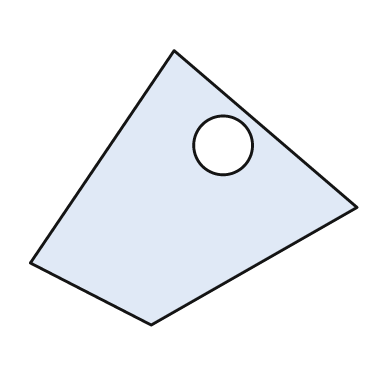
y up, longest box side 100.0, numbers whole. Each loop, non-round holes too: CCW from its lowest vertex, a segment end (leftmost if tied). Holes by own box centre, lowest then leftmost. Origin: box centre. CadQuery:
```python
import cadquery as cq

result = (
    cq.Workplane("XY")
    .moveTo(-13.0, -42.0)
    .lineTo(50.0, -6.0)
    .lineTo(-6.0, 42.0)
    .lineTo(-50.0, -23.0)
    .close()
    .moveTo(9.0, 13.0)
    .circle(9.0)
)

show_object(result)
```